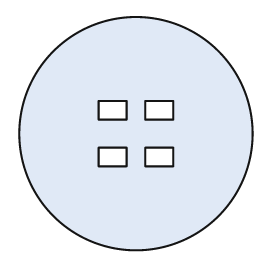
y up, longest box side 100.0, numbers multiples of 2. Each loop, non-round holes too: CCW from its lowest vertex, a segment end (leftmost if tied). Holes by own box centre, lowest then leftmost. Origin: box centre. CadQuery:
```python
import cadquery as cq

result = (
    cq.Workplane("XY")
    .moveTo(0.0, 0.0)
    .circle(50.0)
    .moveTo(-16.0, -14.0)
    .lineTo(-4.0, -14.0)
    .lineTo(-4.0, -6.0)
    .lineTo(-16.0, -6.0)
    .close()
    .moveTo(4.0, -14.0)
    .lineTo(16.0, -14.0)
    .lineTo(16.0, -6.0)
    .lineTo(4.0, -6.0)
    .close()
    .moveTo(-16.0, 6.0)
    .lineTo(-4.0, 6.0)
    .lineTo(-4.0, 14.0)
    .lineTo(-16.0, 14.0)
    .close()
    .moveTo(4.0, 6.0)
    .lineTo(16.0, 6.0)
    .lineTo(16.0, 14.0)
    .lineTo(4.0, 14.0)
    .close()
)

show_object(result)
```